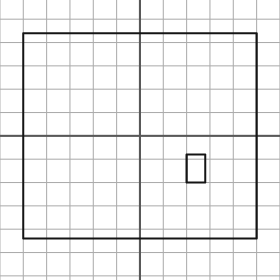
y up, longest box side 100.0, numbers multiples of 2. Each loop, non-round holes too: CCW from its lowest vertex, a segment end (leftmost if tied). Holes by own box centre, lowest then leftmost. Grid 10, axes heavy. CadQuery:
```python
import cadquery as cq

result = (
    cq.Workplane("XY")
    .moveTo(-50.0, -44.0)
    .lineTo(50.0, -44.0)
    .lineTo(50.0, 44.0)
    .lineTo(-50.0, 44.0)
    .close()
    .moveTo(20.0, -20.0)
    .lineTo(28.0, -20.0)
    .lineTo(28.0, -8.0)
    .lineTo(20.0, -8.0)
    .close()
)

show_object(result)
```